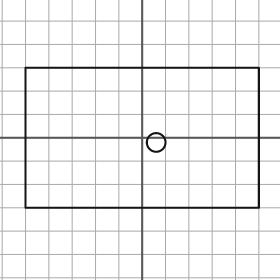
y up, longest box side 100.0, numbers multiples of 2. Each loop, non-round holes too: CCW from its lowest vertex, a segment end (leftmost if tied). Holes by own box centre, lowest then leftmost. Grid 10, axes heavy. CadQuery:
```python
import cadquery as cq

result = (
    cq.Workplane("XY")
    .moveTo(-50.0, -30.0)
    .lineTo(50.0, -30.0)
    .lineTo(50.0, 30.0)
    .lineTo(-50.0, 30.0)
    .close()
    .moveTo(6.0, -2.0)
    .circle(4.0)
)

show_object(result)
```